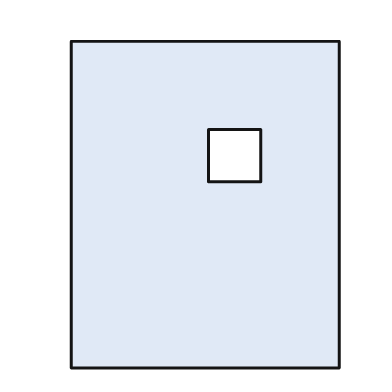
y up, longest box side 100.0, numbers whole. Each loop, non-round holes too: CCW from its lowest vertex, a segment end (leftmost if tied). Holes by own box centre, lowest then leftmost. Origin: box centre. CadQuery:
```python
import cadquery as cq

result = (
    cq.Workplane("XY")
    .moveTo(-41.0, -50.0)
    .lineTo(41.0, -50.0)
    .lineTo(41.0, 50.0)
    .lineTo(-41.0, 50.0)
    .close()
    .moveTo(1.0, 7.0)
    .lineTo(17.0, 7.0)
    .lineTo(17.0, 23.0)
    .lineTo(1.0, 23.0)
    .close()
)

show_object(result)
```